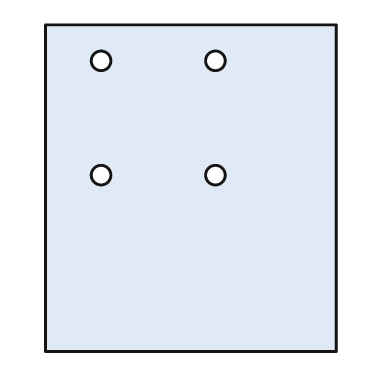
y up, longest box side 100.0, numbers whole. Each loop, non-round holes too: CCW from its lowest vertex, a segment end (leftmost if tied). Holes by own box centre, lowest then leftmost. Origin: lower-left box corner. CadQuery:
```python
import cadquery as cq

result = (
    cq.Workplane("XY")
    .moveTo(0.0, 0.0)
    .lineTo(89.0, 0.0)
    .lineTo(89.0, 100.0)
    .lineTo(0.0, 100.0)
    .close()
    .moveTo(17.0, 54.0)
    .circle(3.0)
    .moveTo(52.0, 54.0)
    .circle(3.0)
    .moveTo(17.0, 89.0)
    .circle(3.0)
    .moveTo(52.0, 89.0)
    .circle(3.0)
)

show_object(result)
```